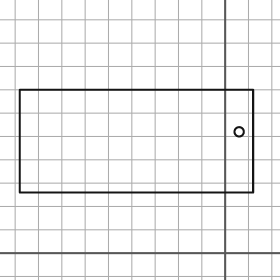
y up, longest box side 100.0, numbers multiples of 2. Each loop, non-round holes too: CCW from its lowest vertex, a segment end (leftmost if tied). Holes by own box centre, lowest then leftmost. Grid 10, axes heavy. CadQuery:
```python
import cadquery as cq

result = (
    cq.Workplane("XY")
    .moveTo(-88.0, 26.0)
    .lineTo(12.0, 26.0)
    .lineTo(12.0, 70.0)
    .lineTo(-88.0, 70.0)
    .close()
    .moveTo(6.0, 52.0)
    .circle(2.0)
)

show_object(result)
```